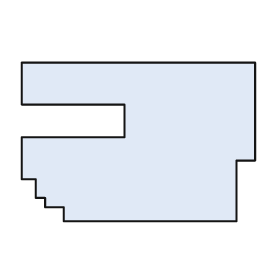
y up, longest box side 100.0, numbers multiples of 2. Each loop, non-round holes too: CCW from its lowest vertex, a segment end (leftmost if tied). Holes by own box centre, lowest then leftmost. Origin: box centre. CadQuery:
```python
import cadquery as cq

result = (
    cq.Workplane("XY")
    .moveTo(-32.0, -34.0)
    .lineTo(42.0, -34.0)
    .lineTo(42.0, -8.0)
    .lineTo(50.0, -8.0)
    .lineTo(50.0, 34.0)
    .lineTo(-50.0, 34.0)
    .lineTo(-50.0, 16.0)
    .lineTo(-6.0, 16.0)
    .lineTo(-6.0, 2.0)
    .lineTo(-50.0, 2.0)
    .lineTo(-50.0, -16.0)
    .lineTo(-44.0, -16.0)
    .lineTo(-44.0, -24.0)
    .lineTo(-40.0, -24.0)
    .lineTo(-40.0, -28.0)
    .lineTo(-32.0, -28.0)
    .close()
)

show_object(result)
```